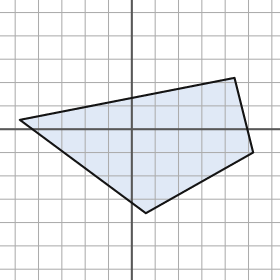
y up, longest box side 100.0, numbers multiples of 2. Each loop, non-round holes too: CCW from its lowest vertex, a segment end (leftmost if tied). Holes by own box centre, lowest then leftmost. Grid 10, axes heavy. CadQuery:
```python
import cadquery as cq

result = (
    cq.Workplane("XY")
    .moveTo(6.0, -36.0)
    .lineTo(52.0, -10.0)
    .lineTo(44.0, 22.0)
    .lineTo(-48.0, 4.0)
    .close()
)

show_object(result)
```